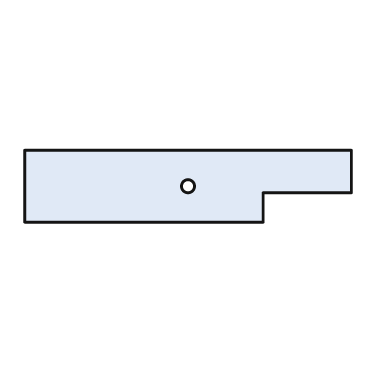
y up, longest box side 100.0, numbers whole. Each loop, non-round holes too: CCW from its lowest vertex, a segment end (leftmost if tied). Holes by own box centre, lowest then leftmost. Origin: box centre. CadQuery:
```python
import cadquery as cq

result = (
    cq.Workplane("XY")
    .moveTo(-50.0, -11.0)
    .lineTo(23.0, -11.0)
    .lineTo(23.0, -2.0)
    .lineTo(50.0, -2.0)
    .lineTo(50.0, 11.0)
    .lineTo(-50.0, 11.0)
    .close()
    .moveTo(0.0, 0.0)
    .circle(2.0)
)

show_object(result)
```